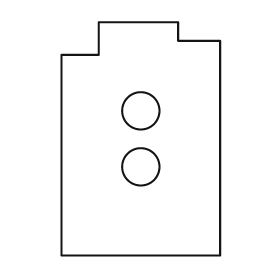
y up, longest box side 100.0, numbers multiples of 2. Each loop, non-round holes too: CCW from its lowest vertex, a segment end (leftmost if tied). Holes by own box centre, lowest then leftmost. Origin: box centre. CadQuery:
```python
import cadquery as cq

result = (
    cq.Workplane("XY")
    .moveTo(-34.0, -50.0)
    .lineTo(34.0, -50.0)
    .lineTo(34.0, 42.0)
    .lineTo(16.0, 42.0)
    .lineTo(16.0, 50.0)
    .lineTo(-18.0, 50.0)
    .lineTo(-18.0, 36.0)
    .lineTo(-34.0, 36.0)
    .close()
    .moveTo(0.0, -12.0)
    .circle(8.0)
    .moveTo(0.0, 12.0)
    .circle(8.0)
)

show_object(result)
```